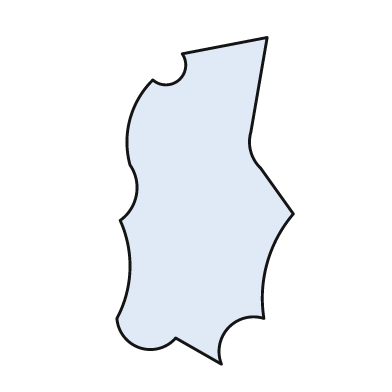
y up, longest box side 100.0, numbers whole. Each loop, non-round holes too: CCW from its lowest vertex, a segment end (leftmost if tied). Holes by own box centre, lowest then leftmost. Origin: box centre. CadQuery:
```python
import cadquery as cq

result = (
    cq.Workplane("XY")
    .moveTo(5.0, -50.0)
    .threePointArc((7.0, -39.0), (18.0, -36.0))
    .threePointArc((19.0, -19.0), (27.0, -4.0))
    .lineTo(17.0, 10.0)
    .threePointArc((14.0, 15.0), (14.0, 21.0))
    .lineTo(19.0, 50.0)
    .lineTo(-7.0, 45.0)
    .threePointArc((-8.0, 37.0), (-16.0, 37.0))
    .threePointArc((-23.0, 25.0), (-23.0, 11.0))
    .threePointArc((-21.0, 2.0), (-26.0, -6.0))
    .threePointArc((-23.0, -21.0), (-27.0, -36.0))
    .threePointArc((-20.0, -45.0), (-9.0, -42.0))
    .close()
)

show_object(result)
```